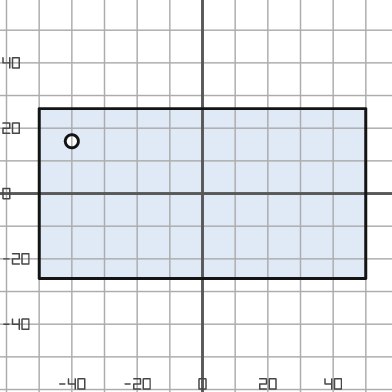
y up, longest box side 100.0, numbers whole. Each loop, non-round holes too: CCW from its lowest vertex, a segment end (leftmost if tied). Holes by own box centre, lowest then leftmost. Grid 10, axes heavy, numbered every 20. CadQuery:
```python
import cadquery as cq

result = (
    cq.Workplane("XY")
    .moveTo(-50.0, -26.0)
    .lineTo(50.0, -26.0)
    .lineTo(50.0, 26.0)
    .lineTo(-50.0, 26.0)
    .close()
    .moveTo(-40.0, 16.0)
    .circle(2.0)
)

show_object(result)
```